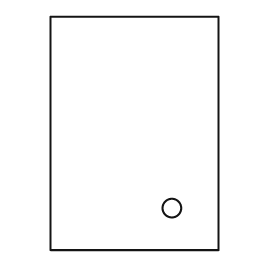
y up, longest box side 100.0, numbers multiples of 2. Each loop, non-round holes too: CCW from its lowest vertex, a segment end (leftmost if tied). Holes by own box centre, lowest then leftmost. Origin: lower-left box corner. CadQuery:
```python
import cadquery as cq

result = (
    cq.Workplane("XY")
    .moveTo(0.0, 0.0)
    .lineTo(72.0, 0.0)
    .lineTo(72.0, 100.0)
    .lineTo(0.0, 100.0)
    .close()
    .moveTo(52.0, 18.0)
    .circle(4.0)
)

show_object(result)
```